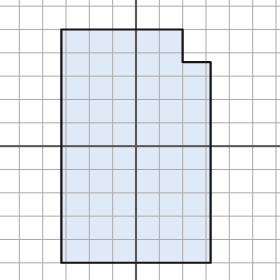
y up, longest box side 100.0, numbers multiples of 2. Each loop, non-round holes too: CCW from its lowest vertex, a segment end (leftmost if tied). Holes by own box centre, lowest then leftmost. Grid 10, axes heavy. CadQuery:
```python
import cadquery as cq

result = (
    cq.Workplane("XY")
    .moveTo(-32.0, -50.0)
    .lineTo(32.0, -50.0)
    .lineTo(32.0, 36.0)
    .lineTo(20.0, 36.0)
    .lineTo(20.0, 50.0)
    .lineTo(-32.0, 50.0)
    .close()
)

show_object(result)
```